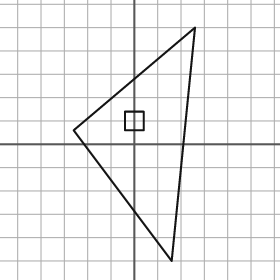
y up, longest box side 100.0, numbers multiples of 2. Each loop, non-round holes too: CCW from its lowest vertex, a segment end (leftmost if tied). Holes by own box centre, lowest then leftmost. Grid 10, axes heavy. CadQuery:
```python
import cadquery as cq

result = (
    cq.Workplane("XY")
    .moveTo(16.0, -50.0)
    .lineTo(26.0, 50.0)
    .lineTo(-26.0, 6.0)
    .close()
    .moveTo(-4.0, 6.0)
    .lineTo(4.0, 6.0)
    .lineTo(4.0, 14.0)
    .lineTo(-4.0, 14.0)
    .close()
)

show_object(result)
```